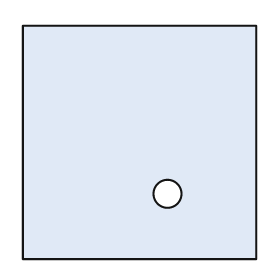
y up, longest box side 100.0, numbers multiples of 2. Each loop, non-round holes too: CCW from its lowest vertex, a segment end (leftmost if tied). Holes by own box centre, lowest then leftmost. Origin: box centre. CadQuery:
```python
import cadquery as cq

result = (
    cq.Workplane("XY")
    .moveTo(-50.0, -50.0)
    .lineTo(50.0, -50.0)
    .lineTo(50.0, 50.0)
    .lineTo(-50.0, 50.0)
    .close()
    .moveTo(12.0, -22.0)
    .circle(6.0)
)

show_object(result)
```